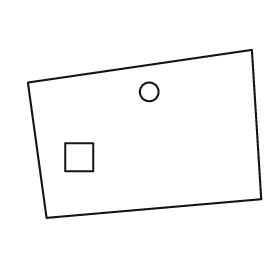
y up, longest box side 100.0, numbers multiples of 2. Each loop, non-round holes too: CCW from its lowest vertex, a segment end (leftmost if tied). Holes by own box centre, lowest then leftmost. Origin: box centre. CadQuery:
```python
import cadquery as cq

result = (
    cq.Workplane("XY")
    .moveTo(-42.0, -36.0)
    .lineTo(50.0, -28.0)
    .lineTo(46.0, 36.0)
    .lineTo(-50.0, 22.0)
    .close()
    .moveTo(-34.0, -16.0)
    .lineTo(-22.0, -16.0)
    .lineTo(-22.0, -4.0)
    .lineTo(-34.0, -4.0)
    .close()
    .moveTo(2.0, 18.0)
    .circle(4.0)
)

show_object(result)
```